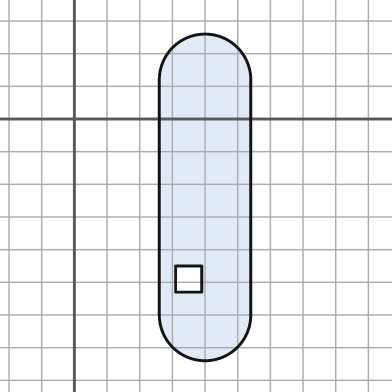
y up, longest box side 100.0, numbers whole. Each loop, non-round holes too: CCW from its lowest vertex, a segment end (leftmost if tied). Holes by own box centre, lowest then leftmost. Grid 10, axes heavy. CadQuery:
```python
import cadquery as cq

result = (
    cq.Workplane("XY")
    .moveTo(26.0, -60.0)
    .threePointArc((40.0, -74.0), (54.0, -60.0))
    .lineTo(54.0, 12.0)
    .threePointArc((40.0, 26.0), (26.0, 12.0))
    .close()
    .moveTo(31.0, -53.0)
    .lineTo(39.0, -53.0)
    .lineTo(39.0, -45.0)
    .lineTo(31.0, -45.0)
    .close()
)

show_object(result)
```